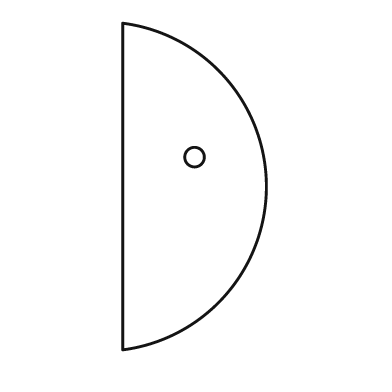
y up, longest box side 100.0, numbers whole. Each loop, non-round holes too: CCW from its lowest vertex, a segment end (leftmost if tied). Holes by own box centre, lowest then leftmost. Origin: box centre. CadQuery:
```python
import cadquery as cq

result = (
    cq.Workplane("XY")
    .moveTo(-22.0, -50.0)
    .threePointArc((22.0, 0.0), (-22.0, 50.0))
    .close()
    .moveTo(0.0, 9.0)
    .circle(3.0)
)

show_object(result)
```